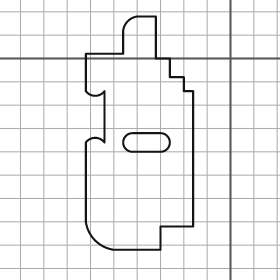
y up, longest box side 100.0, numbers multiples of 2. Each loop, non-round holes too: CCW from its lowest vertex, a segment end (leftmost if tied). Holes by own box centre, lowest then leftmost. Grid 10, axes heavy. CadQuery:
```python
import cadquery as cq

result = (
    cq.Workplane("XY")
    .moveTo(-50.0, -82.0)
    .lineTo(-30.0, -82.0)
    .lineTo(-30.0, -72.0)
    .lineTo(-16.0, -72.0)
    .lineTo(-16.0, -14.0)
    .lineTo(-20.0, -14.0)
    .lineTo(-20.0, -8.0)
    .lineTo(-26.0, -8.0)
    .lineTo(-26.0, 0.0)
    .lineTo(-32.0, 0.0)
    .lineTo(-32.0, 18.0)
    .lineTo(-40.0, 18.0)
    .threePointArc((-44.0, 16.0), (-46.0, 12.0))
    .lineTo(-46.0, 2.0)
    .lineTo(-62.0, 2.0)
    .lineTo(-62.0, -14.0)
    .threePointArc((-58.0, -16.0), (-54.0, -14.0))
    .lineTo(-54.0, -36.0)
    .threePointArc((-58.0, -34.0), (-62.0, -36.0))
    .lineTo(-62.0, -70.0)
    .threePointArc((-58.0, -78.0), (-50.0, -82.0))
    .close()
    .moveTo(-42.0, -40.0)
    .lineTo(-30.0, -40.0)
    .threePointArc((-26.0, -36.0), (-30.0, -32.0))
    .lineTo(-42.0, -32.0)
    .threePointArc((-46.0, -36.0), (-42.0, -40.0))
    .close()
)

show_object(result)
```